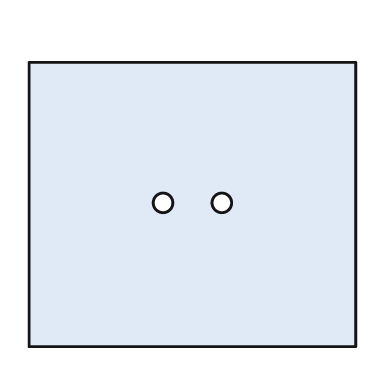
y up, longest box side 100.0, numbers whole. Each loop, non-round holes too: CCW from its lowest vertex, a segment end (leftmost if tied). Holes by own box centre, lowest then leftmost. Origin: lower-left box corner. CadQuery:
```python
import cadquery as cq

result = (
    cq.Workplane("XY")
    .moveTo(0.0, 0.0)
    .lineTo(100.0, 0.0)
    .lineTo(100.0, 87.0)
    .lineTo(0.0, 87.0)
    .close()
    .moveTo(41.0, 44.0)
    .circle(3.0)
    .moveTo(59.0, 44.0)
    .circle(3.0)
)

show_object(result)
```